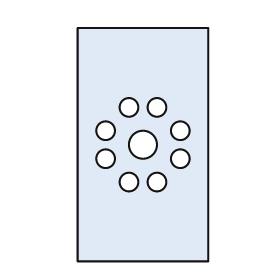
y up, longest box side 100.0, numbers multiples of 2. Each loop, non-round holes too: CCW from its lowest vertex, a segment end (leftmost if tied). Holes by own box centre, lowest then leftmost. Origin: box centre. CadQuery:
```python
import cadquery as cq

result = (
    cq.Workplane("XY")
    .moveTo(-28.0, -50.0)
    .lineTo(28.0, -50.0)
    .lineTo(28.0, 50.0)
    .lineTo(-28.0, 50.0)
    .close()
    .moveTo(-6.0, -16.0)
    .circle(4.0)
    .moveTo(6.0, -16.0)
    .circle(4.0)
    .moveTo(-16.0, -6.0)
    .circle(4.0)
    .moveTo(16.0, -6.0)
    .circle(4.0)
    .moveTo(0.0, 0.0)
    .circle(6.0)
    .moveTo(-16.0, 6.0)
    .circle(4.0)
    .moveTo(16.0, 6.0)
    .circle(4.0)
    .moveTo(-6.0, 16.0)
    .circle(4.0)
    .moveTo(6.0, 16.0)
    .circle(4.0)
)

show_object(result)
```